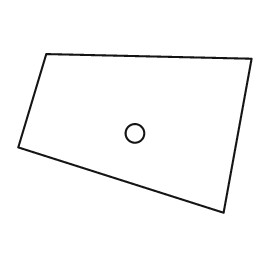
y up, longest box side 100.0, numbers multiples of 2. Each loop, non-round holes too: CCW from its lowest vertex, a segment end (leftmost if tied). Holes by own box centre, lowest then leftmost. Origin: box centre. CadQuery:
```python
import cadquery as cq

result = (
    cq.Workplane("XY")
    .moveTo(38.0, -34.0)
    .lineTo(50.0, 32.0)
    .lineTo(-38.0, 34.0)
    .lineTo(-50.0, -6.0)
    .close()
    .moveTo(0.0, 0.0)
    .circle(4.0)
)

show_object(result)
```